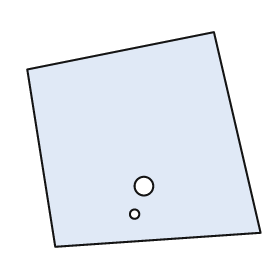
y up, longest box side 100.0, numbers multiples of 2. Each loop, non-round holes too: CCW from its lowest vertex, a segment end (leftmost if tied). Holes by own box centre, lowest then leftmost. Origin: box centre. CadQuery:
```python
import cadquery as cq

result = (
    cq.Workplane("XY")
    .moveTo(-38.0, -46.0)
    .lineTo(50.0, -40.0)
    .lineTo(30.0, 46.0)
    .lineTo(-50.0, 30.0)
    .close()
    .moveTo(-4.0, -32.0)
    .circle(2.0)
    .moveTo(0.0, -20.0)
    .circle(4.0)
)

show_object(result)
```